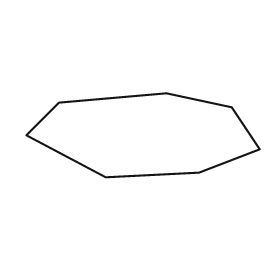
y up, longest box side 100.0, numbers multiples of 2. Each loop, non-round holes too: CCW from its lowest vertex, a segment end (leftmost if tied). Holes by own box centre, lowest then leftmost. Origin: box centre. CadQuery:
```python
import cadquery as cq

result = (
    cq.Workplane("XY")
    .moveTo(-16.0, -18.0)
    .lineTo(24.0, -16.0)
    .lineTo(50.0, -6.0)
    .lineTo(38.0, 12.0)
    .lineTo(10.0, 18.0)
    .lineTo(-36.0, 14.0)
    .lineTo(-50.0, 0.0)
    .close()
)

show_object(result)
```